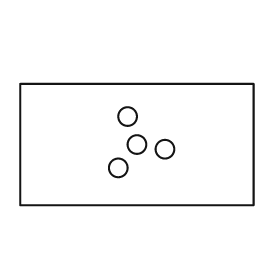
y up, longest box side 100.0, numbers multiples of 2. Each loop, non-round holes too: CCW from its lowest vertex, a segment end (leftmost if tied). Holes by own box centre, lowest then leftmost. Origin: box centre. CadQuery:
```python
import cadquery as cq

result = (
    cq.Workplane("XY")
    .moveTo(-50.0, -26.0)
    .lineTo(50.0, -26.0)
    .lineTo(50.0, 26.0)
    .lineTo(-50.0, 26.0)
    .close()
    .moveTo(-8.0, -10.0)
    .circle(4.0)
    .moveTo(12.0, -2.0)
    .circle(4.0)
    .moveTo(0.0, 0.0)
    .circle(4.0)
    .moveTo(-4.0, 12.0)
    .circle(4.0)
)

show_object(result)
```